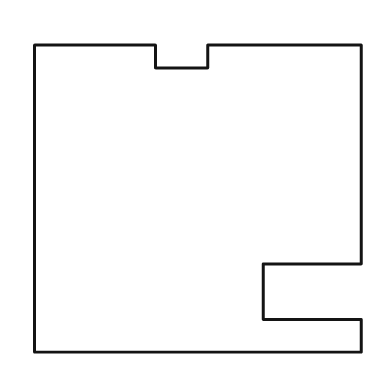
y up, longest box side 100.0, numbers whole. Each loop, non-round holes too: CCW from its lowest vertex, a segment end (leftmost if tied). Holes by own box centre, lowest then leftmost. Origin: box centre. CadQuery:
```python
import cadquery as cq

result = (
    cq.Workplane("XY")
    .moveTo(-50.0, -47.0)
    .lineTo(50.0, -47.0)
    .lineTo(50.0, -37.0)
    .lineTo(20.0, -37.0)
    .lineTo(20.0, -20.0)
    .lineTo(50.0, -20.0)
    .lineTo(50.0, 47.0)
    .lineTo(3.0, 47.0)
    .lineTo(3.0, 40.0)
    .lineTo(-13.0, 40.0)
    .lineTo(-13.0, 47.0)
    .lineTo(-50.0, 47.0)
    .close()
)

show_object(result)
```